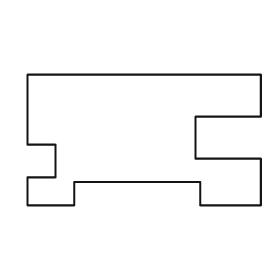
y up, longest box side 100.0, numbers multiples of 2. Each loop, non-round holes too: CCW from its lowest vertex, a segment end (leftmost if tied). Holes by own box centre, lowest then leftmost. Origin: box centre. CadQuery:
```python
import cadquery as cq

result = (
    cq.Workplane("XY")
    .moveTo(-50.0, -28.0)
    .lineTo(-30.0, -28.0)
    .lineTo(-30.0, -18.0)
    .lineTo(24.0, -18.0)
    .lineTo(24.0, -28.0)
    .lineTo(50.0, -28.0)
    .lineTo(50.0, -8.0)
    .lineTo(22.0, -8.0)
    .lineTo(22.0, 10.0)
    .lineTo(50.0, 10.0)
    .lineTo(50.0, 28.0)
    .lineTo(-50.0, 28.0)
    .lineTo(-50.0, -2.0)
    .lineTo(-38.0, -2.0)
    .lineTo(-38.0, -16.0)
    .lineTo(-50.0, -16.0)
    .close()
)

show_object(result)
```